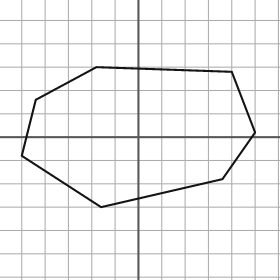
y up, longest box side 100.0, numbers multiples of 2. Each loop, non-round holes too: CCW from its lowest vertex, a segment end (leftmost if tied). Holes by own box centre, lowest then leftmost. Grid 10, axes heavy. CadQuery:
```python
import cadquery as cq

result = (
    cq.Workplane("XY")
    .moveTo(-16.0, -30.0)
    .lineTo(36.0, -18.0)
    .lineTo(50.0, 2.0)
    .lineTo(40.0, 28.0)
    .lineTo(-18.0, 30.0)
    .lineTo(-44.0, 16.0)
    .lineTo(-50.0, -8.0)
    .close()
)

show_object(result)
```